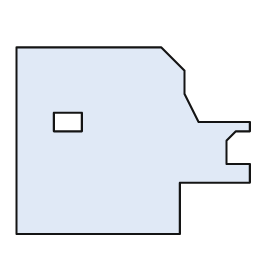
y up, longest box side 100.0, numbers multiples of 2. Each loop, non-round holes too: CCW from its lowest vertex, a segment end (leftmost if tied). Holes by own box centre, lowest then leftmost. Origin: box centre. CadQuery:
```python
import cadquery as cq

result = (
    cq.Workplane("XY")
    .moveTo(-50.0, -40.0)
    .lineTo(20.0, -40.0)
    .lineTo(20.0, -18.0)
    .lineTo(50.0, -18.0)
    .lineTo(50.0, -10.0)
    .lineTo(40.0, -10.0)
    .lineTo(40.0, 0.0)
    .lineTo(44.0, 4.0)
    .lineTo(50.0, 4.0)
    .lineTo(50.0, 8.0)
    .lineTo(28.0, 8.0)
    .lineTo(22.0, 20.0)
    .lineTo(22.0, 30.0)
    .lineTo(12.0, 40.0)
    .lineTo(-50.0, 40.0)
    .close()
    .moveTo(-34.0, 4.0)
    .lineTo(-22.0, 4.0)
    .lineTo(-22.0, 12.0)
    .lineTo(-34.0, 12.0)
    .close()
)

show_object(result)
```